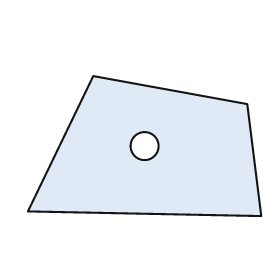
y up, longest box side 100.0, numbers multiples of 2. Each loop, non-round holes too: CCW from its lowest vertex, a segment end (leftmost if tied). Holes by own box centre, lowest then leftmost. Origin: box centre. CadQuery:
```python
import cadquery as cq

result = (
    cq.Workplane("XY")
    .moveTo(50.0, -30.0)
    .lineTo(44.0, 18.0)
    .lineTo(-22.0, 30.0)
    .lineTo(-50.0, -28.0)
    .close()
    .moveTo(0.0, 0.0)
    .circle(6.0)
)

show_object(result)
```